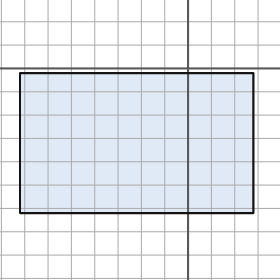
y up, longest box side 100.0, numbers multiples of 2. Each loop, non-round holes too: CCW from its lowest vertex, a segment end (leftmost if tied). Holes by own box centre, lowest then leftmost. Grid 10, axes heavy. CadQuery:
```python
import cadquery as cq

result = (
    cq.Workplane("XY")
    .moveTo(-72.0, -62.0)
    .lineTo(28.0, -62.0)
    .lineTo(28.0, -2.0)
    .lineTo(-72.0, -2.0)
    .close()
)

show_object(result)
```